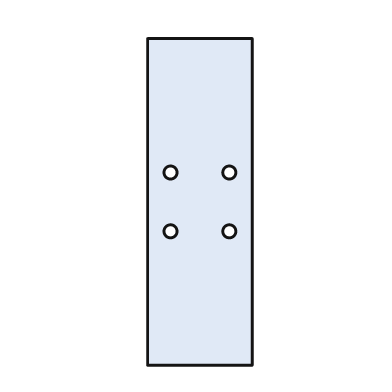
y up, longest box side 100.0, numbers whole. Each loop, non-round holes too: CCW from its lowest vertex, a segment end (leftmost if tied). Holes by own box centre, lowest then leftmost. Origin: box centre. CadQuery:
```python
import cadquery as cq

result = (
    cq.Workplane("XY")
    .moveTo(-16.0, -50.0)
    .lineTo(16.0, -50.0)
    .lineTo(16.0, 50.0)
    .lineTo(-16.0, 50.0)
    .close()
    .moveTo(-9.0, -9.0)
    .circle(2.0)
    .moveTo(9.0, -9.0)
    .circle(2.0)
    .moveTo(-9.0, 9.0)
    .circle(2.0)
    .moveTo(9.0, 9.0)
    .circle(2.0)
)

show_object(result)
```